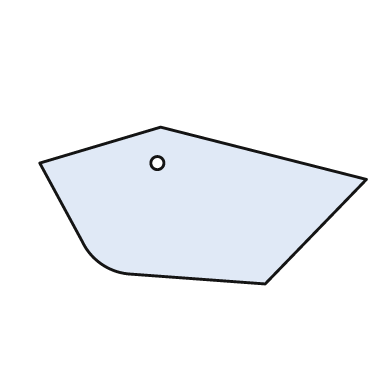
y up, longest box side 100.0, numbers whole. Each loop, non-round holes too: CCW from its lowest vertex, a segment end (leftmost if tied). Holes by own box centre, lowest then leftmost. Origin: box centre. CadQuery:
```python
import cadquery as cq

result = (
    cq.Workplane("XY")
    .moveTo(19.0, -24.0)
    .lineTo(50.0, 8.0)
    .lineTo(-13.0, 24.0)
    .lineTo(-50.0, 13.0)
    .lineTo(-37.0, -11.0)
    .threePointArc((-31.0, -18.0), (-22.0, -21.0))
    .close()
    .moveTo(-14.0, 13.0)
    .circle(2.0)
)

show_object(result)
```